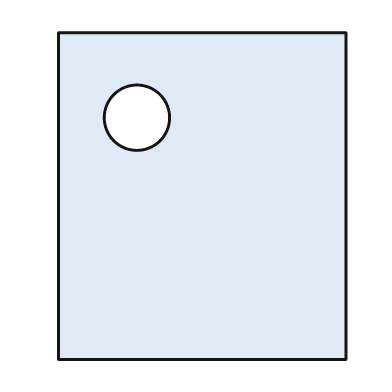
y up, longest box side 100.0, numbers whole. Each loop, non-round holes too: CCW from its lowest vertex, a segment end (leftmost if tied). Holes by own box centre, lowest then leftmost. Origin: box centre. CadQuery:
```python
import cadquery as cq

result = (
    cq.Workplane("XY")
    .moveTo(-44.0, -50.0)
    .lineTo(44.0, -50.0)
    .lineTo(44.0, 50.0)
    .lineTo(-44.0, 50.0)
    .close()
    .moveTo(-20.0, 24.0)
    .circle(10.0)
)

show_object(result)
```